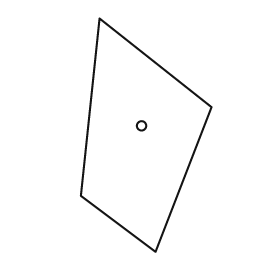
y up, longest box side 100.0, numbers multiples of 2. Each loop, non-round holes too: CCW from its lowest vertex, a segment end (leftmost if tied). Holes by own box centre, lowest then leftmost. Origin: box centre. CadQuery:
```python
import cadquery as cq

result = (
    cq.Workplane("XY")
    .moveTo(4.0, -50.0)
    .lineTo(28.0, 12.0)
    .lineTo(-20.0, 50.0)
    .lineTo(-28.0, -26.0)
    .close()
    .moveTo(-2.0, 4.0)
    .circle(2.0)
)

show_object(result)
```